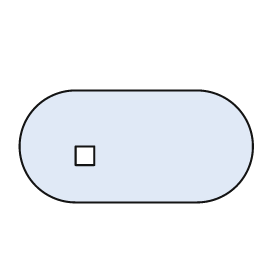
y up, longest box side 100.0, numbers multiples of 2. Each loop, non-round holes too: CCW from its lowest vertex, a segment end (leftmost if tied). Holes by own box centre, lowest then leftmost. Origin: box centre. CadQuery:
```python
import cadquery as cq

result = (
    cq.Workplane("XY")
    .moveTo(-26.0, -24.0)
    .lineTo(26.0, -24.0)
    .threePointArc((50.0, 0.0), (26.0, 24.0))
    .lineTo(-26.0, 24.0)
    .threePointArc((-50.0, 0.0), (-26.0, -24.0))
    .close()
    .moveTo(-26.0, -8.0)
    .lineTo(-18.0, -8.0)
    .lineTo(-18.0, 0.0)
    .lineTo(-26.0, 0.0)
    .close()
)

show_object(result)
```